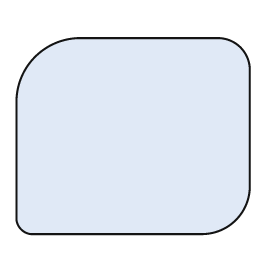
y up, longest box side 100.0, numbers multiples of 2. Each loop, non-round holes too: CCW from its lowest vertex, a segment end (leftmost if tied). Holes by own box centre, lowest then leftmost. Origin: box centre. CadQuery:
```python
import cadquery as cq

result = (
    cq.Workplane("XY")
    .moveTo(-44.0, -42.0)
    .lineTo(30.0, -42.0)
    .threePointArc((44.0, -36.0), (50.0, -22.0))
    .lineTo(50.0, 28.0)
    .threePointArc((46.0, 38.0), (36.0, 42.0))
    .lineTo(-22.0, 42.0)
    .threePointArc((-42.0, 34.0), (-50.0, 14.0))
    .lineTo(-50.0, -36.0)
    .threePointArc((-48.0, -40.0), (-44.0, -42.0))
    .close()
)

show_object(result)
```